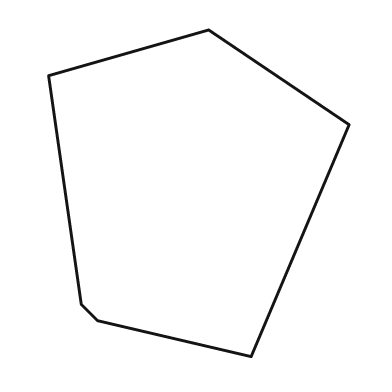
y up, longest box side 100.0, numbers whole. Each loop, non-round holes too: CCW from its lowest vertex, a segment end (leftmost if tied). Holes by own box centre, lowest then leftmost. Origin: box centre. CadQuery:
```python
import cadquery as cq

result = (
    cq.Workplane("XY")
    .moveTo(16.0, -50.0)
    .lineTo(46.0, 21.0)
    .lineTo(3.0, 50.0)
    .lineTo(-46.0, 36.0)
    .lineTo(-36.0, -34.0)
    .lineTo(-31.0, -39.0)
    .close()
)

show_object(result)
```